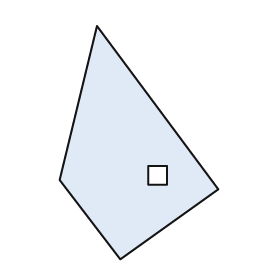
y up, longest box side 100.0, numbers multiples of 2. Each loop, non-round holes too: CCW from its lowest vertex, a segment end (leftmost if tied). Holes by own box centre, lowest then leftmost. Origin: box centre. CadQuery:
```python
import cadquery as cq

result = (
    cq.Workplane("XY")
    .moveTo(-8.0, -50.0)
    .lineTo(34.0, -20.0)
    .lineTo(-18.0, 50.0)
    .lineTo(-34.0, -16.0)
    .close()
    .moveTo(4.0, -18.0)
    .lineTo(12.0, -18.0)
    .lineTo(12.0, -10.0)
    .lineTo(4.0, -10.0)
    .close()
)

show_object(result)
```